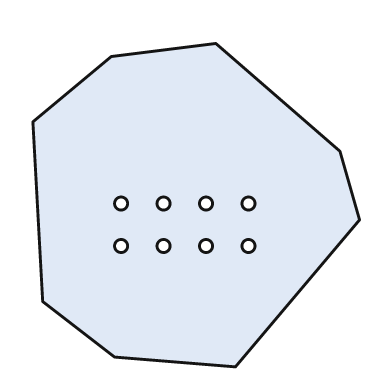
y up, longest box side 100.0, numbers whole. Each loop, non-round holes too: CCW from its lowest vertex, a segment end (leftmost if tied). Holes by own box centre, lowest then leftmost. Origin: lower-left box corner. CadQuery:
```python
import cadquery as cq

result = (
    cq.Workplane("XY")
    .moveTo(62.0, 0.0)
    .lineTo(100.0, 45.0)
    .lineTo(94.0, 66.0)
    .lineTo(56.0, 99.0)
    .lineTo(24.0, 95.0)
    .lineTo(0.0, 75.0)
    .lineTo(3.0, 20.0)
    .lineTo(25.0, 3.0)
    .close()
    .moveTo(27.0, 37.0)
    .circle(2.0)
    .moveTo(40.0, 37.0)
    .circle(2.0)
    .moveTo(53.0, 37.0)
    .circle(2.0)
    .moveTo(66.0, 37.0)
    .circle(2.0)
    .moveTo(27.0, 50.0)
    .circle(2.0)
    .moveTo(40.0, 50.0)
    .circle(2.0)
    .moveTo(53.0, 50.0)
    .circle(2.0)
    .moveTo(66.0, 50.0)
    .circle(2.0)
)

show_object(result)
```